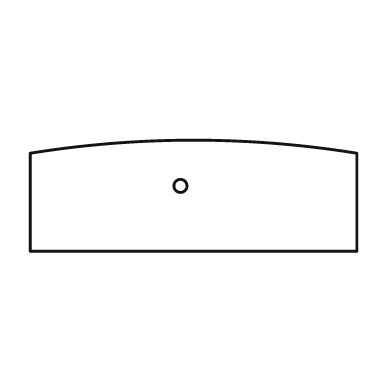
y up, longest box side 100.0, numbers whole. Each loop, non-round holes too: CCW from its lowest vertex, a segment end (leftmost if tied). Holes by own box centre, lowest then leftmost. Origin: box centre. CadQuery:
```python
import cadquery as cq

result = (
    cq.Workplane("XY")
    .moveTo(-50.0, -17.0)
    .lineTo(50.0, -17.0)
    .lineTo(50.0, 13.0)
    .threePointArc((0.0, 17.0), (-50.0, 13.0))
    .close()
    .moveTo(-4.0, 3.0)
    .circle(2.0)
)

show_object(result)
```